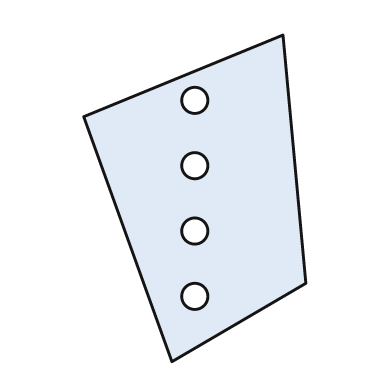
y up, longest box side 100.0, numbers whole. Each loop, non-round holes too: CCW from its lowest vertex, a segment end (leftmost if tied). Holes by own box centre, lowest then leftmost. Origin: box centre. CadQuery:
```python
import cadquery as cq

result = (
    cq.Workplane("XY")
    .moveTo(-7.0, -50.0)
    .lineTo(34.0, -26.0)
    .lineTo(27.0, 50.0)
    .lineTo(-34.0, 25.0)
    .close()
    .moveTo(0.0, -30.0)
    .circle(4.0)
    .moveTo(0.0, -10.0)
    .circle(4.0)
    .moveTo(0.0, 10.0)
    .circle(4.0)
    .moveTo(0.0, 30.0)
    .circle(4.0)
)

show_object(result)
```